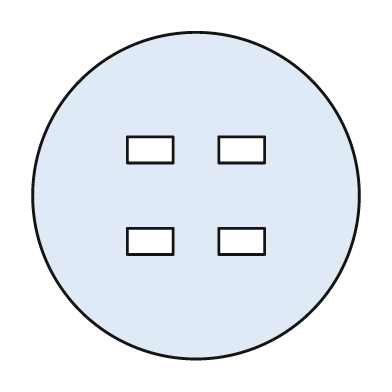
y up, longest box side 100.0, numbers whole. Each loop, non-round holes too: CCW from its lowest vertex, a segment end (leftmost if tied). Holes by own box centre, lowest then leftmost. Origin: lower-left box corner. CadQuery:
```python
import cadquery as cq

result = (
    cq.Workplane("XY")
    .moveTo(50.0, 50.0)
    .circle(50.0)
    .moveTo(29.0, 32.0)
    .lineTo(43.0, 32.0)
    .lineTo(43.0, 40.0)
    .lineTo(29.0, 40.0)
    .close()
    .moveTo(57.0, 32.0)
    .lineTo(71.0, 32.0)
    .lineTo(71.0, 40.0)
    .lineTo(57.0, 40.0)
    .close()
    .moveTo(29.0, 60.0)
    .lineTo(43.0, 60.0)
    .lineTo(43.0, 68.0)
    .lineTo(29.0, 68.0)
    .close()
    .moveTo(57.0, 60.0)
    .lineTo(71.0, 60.0)
    .lineTo(71.0, 68.0)
    .lineTo(57.0, 68.0)
    .close()
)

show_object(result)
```